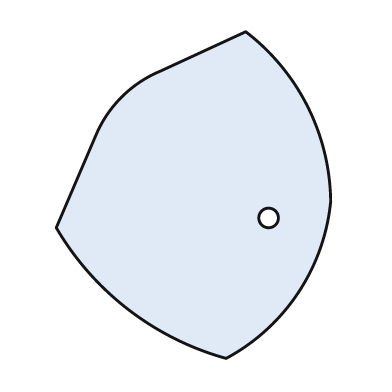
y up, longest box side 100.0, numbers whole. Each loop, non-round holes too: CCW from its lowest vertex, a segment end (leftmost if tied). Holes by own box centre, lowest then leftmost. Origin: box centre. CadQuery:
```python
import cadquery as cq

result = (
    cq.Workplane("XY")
    .moveTo(10.0, -50.0)
    .threePointArc((32.0, -30.0), (42.0, -2.0))
    .threePointArc((35.0, 27.0), (16.0, 50.0))
    .lineTo(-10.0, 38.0)
    .threePointArc((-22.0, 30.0), (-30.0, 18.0))
    .lineTo(-42.0, -10.0)
    .threePointArc((-20.0, -35.0), (10.0, -50.0))
    .close()
    .moveTo(23.0, -7.0)
    .circle(3.0)
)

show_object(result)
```